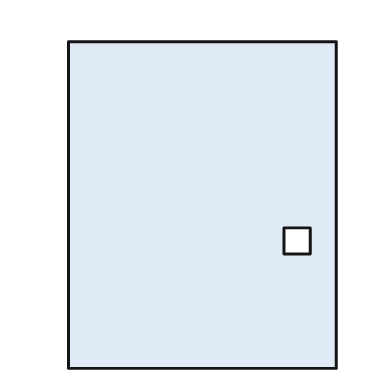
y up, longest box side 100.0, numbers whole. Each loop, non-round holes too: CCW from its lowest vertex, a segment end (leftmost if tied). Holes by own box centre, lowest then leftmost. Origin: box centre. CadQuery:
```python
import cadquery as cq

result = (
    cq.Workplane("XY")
    .moveTo(-41.0, -50.0)
    .lineTo(41.0, -50.0)
    .lineTo(41.0, 50.0)
    .lineTo(-41.0, 50.0)
    .close()
    .moveTo(25.0, -15.0)
    .lineTo(33.0, -15.0)
    .lineTo(33.0, -7.0)
    .lineTo(25.0, -7.0)
    .close()
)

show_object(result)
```